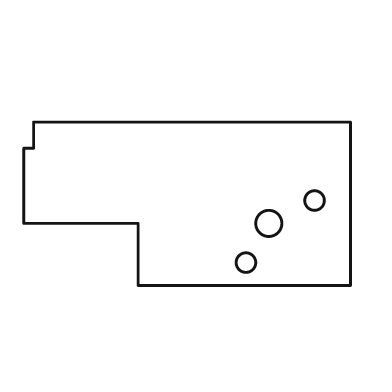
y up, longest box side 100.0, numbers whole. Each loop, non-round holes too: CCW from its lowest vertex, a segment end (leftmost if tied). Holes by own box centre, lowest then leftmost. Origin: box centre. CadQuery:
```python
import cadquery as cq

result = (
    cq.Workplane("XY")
    .moveTo(-15.0, -25.0)
    .lineTo(50.0, -25.0)
    .lineTo(50.0, 25.0)
    .lineTo(-47.0, 25.0)
    .lineTo(-47.0, 17.0)
    .lineTo(-50.0, 17.0)
    .lineTo(-50.0, -6.0)
    .lineTo(-15.0, -6.0)
    .close()
    .moveTo(18.0, -18.0)
    .circle(3.0)
    .moveTo(25.0, -6.0)
    .circle(4.0)
    .moveTo(39.0, 1.0)
    .circle(3.0)
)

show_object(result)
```